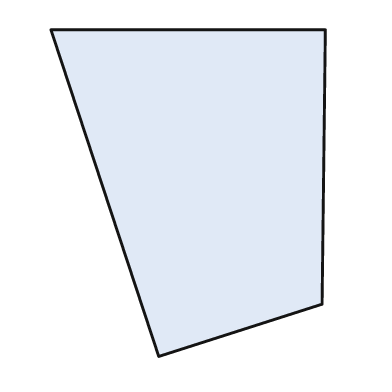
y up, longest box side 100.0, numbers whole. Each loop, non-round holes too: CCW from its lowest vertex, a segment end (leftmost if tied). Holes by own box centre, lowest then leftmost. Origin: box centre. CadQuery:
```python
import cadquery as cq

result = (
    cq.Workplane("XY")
    .moveTo(-9.0, -50.0)
    .lineTo(41.0, -34.0)
    .lineTo(42.0, 50.0)
    .lineTo(-42.0, 50.0)
    .close()
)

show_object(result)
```